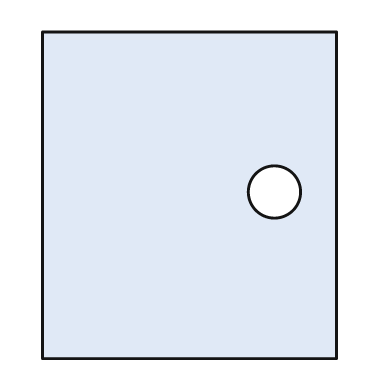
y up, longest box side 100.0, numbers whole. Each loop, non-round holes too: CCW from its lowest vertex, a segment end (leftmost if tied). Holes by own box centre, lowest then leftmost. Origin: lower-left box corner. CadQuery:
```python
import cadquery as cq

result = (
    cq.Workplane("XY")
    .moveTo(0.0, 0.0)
    .lineTo(90.0, 0.0)
    .lineTo(90.0, 100.0)
    .lineTo(0.0, 100.0)
    .close()
    .moveTo(71.0, 51.0)
    .circle(8.0)
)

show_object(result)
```